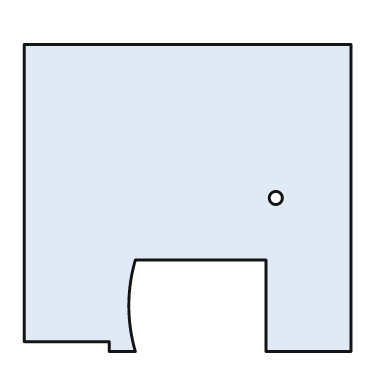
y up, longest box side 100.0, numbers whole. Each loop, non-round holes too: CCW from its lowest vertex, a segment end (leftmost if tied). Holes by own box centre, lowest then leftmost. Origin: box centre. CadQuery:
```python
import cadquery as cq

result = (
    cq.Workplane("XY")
    .moveTo(-24.0, -47.0)
    .lineTo(-16.0, -47.0)
    .threePointArc((-18.0, -33.0), (-16.0, -19.0))
    .lineTo(24.0, -19.0)
    .lineTo(24.0, -47.0)
    .lineTo(50.0, -47.0)
    .lineTo(50.0, 47.0)
    .lineTo(-50.0, 47.0)
    .lineTo(-50.0, -44.0)
    .lineTo(-24.0, -44.0)
    .close()
    .moveTo(27.0, 0.0)
    .circle(2.0)
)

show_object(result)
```